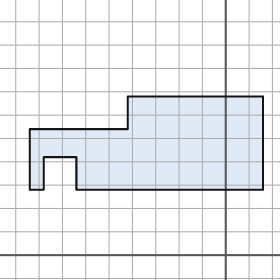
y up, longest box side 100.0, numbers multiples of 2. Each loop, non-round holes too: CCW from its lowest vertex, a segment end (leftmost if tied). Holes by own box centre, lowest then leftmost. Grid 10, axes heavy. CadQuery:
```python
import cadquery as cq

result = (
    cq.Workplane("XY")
    .moveTo(-84.0, 28.0)
    .lineTo(-78.0, 28.0)
    .lineTo(-78.0, 42.0)
    .lineTo(-64.0, 42.0)
    .lineTo(-64.0, 28.0)
    .lineTo(16.0, 28.0)
    .lineTo(16.0, 68.0)
    .lineTo(-42.0, 68.0)
    .lineTo(-42.0, 54.0)
    .lineTo(-84.0, 54.0)
    .close()
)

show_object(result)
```